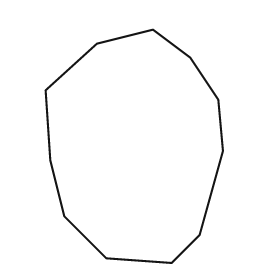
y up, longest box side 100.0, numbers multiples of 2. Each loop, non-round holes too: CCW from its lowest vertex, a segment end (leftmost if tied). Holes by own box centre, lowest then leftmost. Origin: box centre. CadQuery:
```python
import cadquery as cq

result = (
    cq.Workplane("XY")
    .moveTo(16.0, -50.0)
    .lineTo(28.0, -38.0)
    .lineTo(38.0, -2.0)
    .lineTo(36.0, 20.0)
    .lineTo(24.0, 38.0)
    .lineTo(8.0, 50.0)
    .lineTo(-16.0, 44.0)
    .lineTo(-38.0, 24.0)
    .lineTo(-36.0, -6.0)
    .lineTo(-30.0, -30.0)
    .lineTo(-12.0, -48.0)
    .close()
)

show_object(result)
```